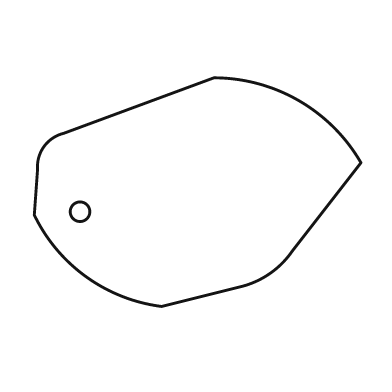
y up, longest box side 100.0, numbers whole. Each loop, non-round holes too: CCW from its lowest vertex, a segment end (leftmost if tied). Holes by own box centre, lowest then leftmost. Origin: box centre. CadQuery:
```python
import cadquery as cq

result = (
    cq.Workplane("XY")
    .moveTo(-11.0, -35.0)
    .lineTo(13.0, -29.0)
    .threePointArc((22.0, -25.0), (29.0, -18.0))
    .lineTo(50.0, 9.0)
    .threePointArc((31.0, 28.0), (5.0, 35.0))
    .lineTo(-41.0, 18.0)
    .threePointArc((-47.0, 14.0), (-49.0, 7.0))
    .lineTo(-50.0, -7.0)
    .threePointArc((-34.0, -26.0), (-11.0, -35.0))
    .close()
    .moveTo(-36.0, -6.0)
    .circle(3.0)
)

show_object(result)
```